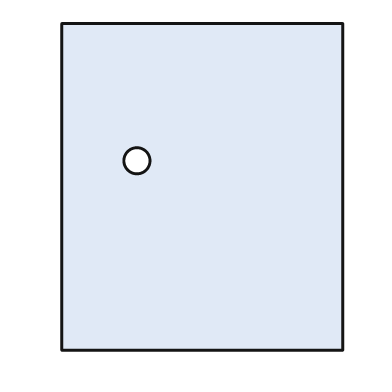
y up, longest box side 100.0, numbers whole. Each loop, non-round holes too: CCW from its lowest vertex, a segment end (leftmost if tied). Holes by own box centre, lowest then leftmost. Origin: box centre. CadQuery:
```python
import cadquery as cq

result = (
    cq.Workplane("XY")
    .moveTo(-43.0, -50.0)
    .lineTo(43.0, -50.0)
    .lineTo(43.0, 50.0)
    .lineTo(-43.0, 50.0)
    .close()
    .moveTo(-20.0, 8.0)
    .circle(4.0)
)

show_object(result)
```